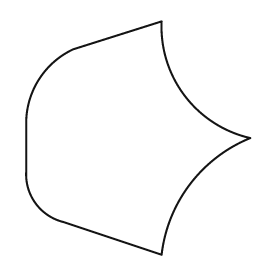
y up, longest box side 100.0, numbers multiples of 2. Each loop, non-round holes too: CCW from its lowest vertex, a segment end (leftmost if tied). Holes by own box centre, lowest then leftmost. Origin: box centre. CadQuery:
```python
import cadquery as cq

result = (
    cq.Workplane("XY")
    .moveTo(10.0, -50.0)
    .threePointArc((22.0, -20.0), (48.0, 0.0))
    .threePointArc((20.0, 18.0), (10.0, 50.0))
    .lineTo(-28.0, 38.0)
    .threePointArc((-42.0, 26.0), (-48.0, 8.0))
    .lineTo(-48.0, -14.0)
    .threePointArc((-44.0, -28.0), (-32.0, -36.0))
    .close()
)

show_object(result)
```